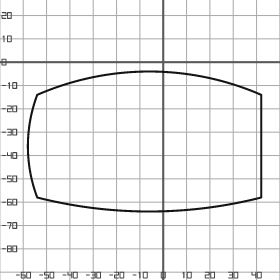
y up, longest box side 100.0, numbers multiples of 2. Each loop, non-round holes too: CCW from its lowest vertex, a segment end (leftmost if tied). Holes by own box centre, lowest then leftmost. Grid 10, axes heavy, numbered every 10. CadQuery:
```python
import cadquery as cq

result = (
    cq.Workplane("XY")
    .moveTo(-54.0, -58.0)
    .threePointArc((-6.0, -64.0), (42.0, -58.0))
    .lineTo(42.0, -14.0)
    .threePointArc((-6.0, -4.0), (-54.0, -14.0))
    .threePointArc((-58.0, -36.0), (-54.0, -58.0))
    .close()
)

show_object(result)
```